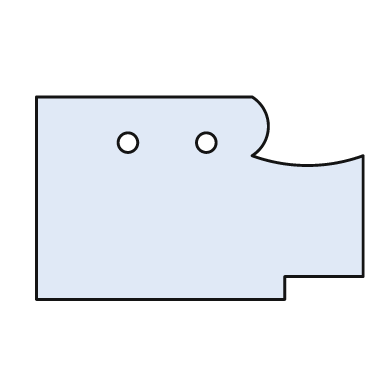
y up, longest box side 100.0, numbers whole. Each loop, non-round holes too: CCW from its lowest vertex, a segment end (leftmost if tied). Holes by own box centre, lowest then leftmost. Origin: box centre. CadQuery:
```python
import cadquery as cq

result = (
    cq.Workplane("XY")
    .moveTo(-50.0, -31.0)
    .lineTo(26.0, -31.0)
    .lineTo(26.0, -24.0)
    .lineTo(50.0, -24.0)
    .lineTo(50.0, 13.0)
    .threePointArc((33.0, 10.0), (16.0, 13.0))
    .threePointArc((21.0, 22.0), (16.0, 31.0))
    .lineTo(-50.0, 31.0)
    .close()
    .moveTo(-22.0, 17.0)
    .circle(3.0)
    .moveTo(2.0, 17.0)
    .circle(3.0)
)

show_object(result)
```